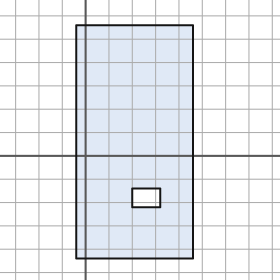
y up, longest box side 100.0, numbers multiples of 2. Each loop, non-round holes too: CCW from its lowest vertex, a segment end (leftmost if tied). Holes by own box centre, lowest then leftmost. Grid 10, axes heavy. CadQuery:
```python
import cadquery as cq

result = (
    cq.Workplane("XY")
    .moveTo(-4.0, -44.0)
    .lineTo(46.0, -44.0)
    .lineTo(46.0, 56.0)
    .lineTo(-4.0, 56.0)
    .close()
    .moveTo(20.0, -22.0)
    .lineTo(32.0, -22.0)
    .lineTo(32.0, -14.0)
    .lineTo(20.0, -14.0)
    .close()
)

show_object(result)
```